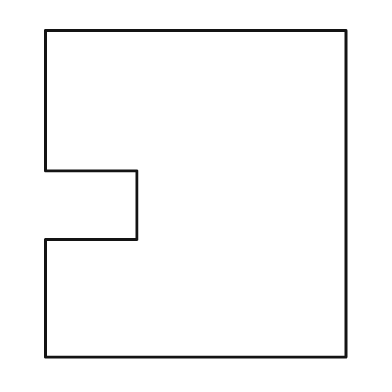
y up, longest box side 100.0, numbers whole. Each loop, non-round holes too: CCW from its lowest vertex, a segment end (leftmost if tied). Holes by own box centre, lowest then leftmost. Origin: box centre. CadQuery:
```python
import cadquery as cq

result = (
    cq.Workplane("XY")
    .moveTo(-46.0, -50.0)
    .lineTo(46.0, -50.0)
    .lineTo(46.0, 50.0)
    .lineTo(-46.0, 50.0)
    .lineTo(-46.0, 7.0)
    .lineTo(-18.0, 7.0)
    .lineTo(-18.0, -14.0)
    .lineTo(-46.0, -14.0)
    .close()
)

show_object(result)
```